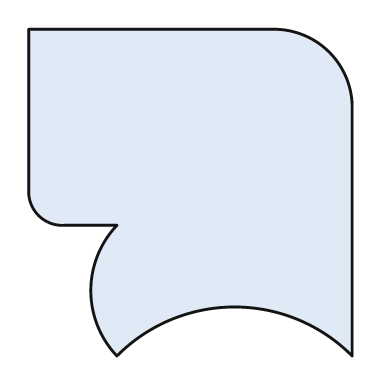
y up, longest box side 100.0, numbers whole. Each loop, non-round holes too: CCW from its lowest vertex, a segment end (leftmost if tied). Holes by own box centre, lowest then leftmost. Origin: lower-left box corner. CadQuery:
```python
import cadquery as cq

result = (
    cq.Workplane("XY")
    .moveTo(27.0, 0.0)
    .threePointArc((63.0, 15.0), (99.0, 0.0))
    .lineTo(99.0, 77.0)
    .threePointArc((92.0, 93.0), (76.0, 100.0))
    .lineTo(0.0, 100.0)
    .lineTo(0.0, 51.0)
    .threePointArc((3.0, 43.0), (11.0, 40.0))
    .lineTo(27.0, 40.0)
    .threePointArc((19.0, 20.0), (27.0, 0.0))
    .close()
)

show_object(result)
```